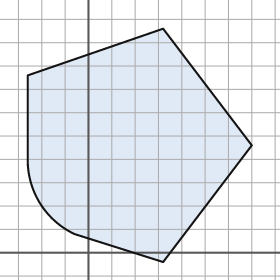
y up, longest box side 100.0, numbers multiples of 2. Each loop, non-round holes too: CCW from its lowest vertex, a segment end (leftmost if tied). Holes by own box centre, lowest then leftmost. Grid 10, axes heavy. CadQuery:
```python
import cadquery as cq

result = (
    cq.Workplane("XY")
    .moveTo(32.0, -4.0)
    .lineTo(70.0, 46.0)
    .lineTo(32.0, 96.0)
    .lineTo(-26.0, 76.0)
    .lineTo(-26.0, 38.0)
    .threePointArc((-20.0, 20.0), (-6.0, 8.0))
    .close()
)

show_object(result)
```